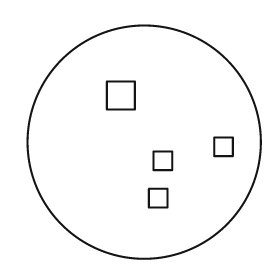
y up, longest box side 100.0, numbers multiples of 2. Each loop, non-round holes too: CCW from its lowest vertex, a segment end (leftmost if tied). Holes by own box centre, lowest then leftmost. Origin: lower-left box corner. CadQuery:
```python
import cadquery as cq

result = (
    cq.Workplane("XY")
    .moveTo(50.0, 50.0)
    .circle(50.0)
    .moveTo(52.0, 22.0)
    .lineTo(60.0, 22.0)
    .lineTo(60.0, 30.0)
    .lineTo(52.0, 30.0)
    .close()
    .moveTo(54.0, 38.0)
    .lineTo(62.0, 38.0)
    .lineTo(62.0, 46.0)
    .lineTo(54.0, 46.0)
    .close()
    .moveTo(80.0, 44.0)
    .lineTo(88.0, 44.0)
    .lineTo(88.0, 52.0)
    .lineTo(80.0, 52.0)
    .close()
    .moveTo(34.0, 64.0)
    .lineTo(46.0, 64.0)
    .lineTo(46.0, 76.0)
    .lineTo(34.0, 76.0)
    .close()
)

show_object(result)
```